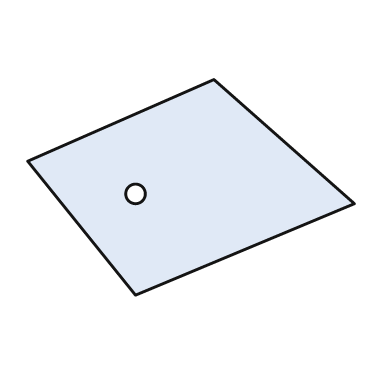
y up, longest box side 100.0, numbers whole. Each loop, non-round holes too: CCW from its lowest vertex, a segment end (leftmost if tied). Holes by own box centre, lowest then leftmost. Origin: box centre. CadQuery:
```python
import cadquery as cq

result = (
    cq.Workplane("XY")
    .moveTo(-17.0, -33.0)
    .lineTo(50.0, -5.0)
    .lineTo(7.0, 33.0)
    .lineTo(-50.0, 8.0)
    .close()
    .moveTo(-17.0, -2.0)
    .circle(3.0)
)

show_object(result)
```